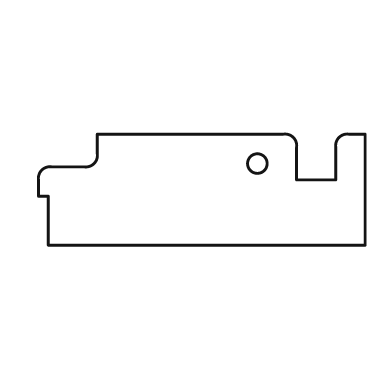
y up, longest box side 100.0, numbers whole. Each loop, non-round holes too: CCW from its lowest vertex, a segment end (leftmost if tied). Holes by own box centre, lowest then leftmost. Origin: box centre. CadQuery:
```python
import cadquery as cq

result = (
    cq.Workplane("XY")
    .moveTo(-47.0, -17.0)
    .lineTo(50.0, -17.0)
    .lineTo(50.0, 17.0)
    .lineTo(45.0, 17.0)
    .threePointArc((42.0, 16.0), (41.0, 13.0))
    .lineTo(41.0, 3.0)
    .lineTo(29.0, 3.0)
    .lineTo(29.0, 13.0)
    .threePointArc((28.0, 16.0), (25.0, 17.0))
    .lineTo(-32.0, 17.0)
    .lineTo(-32.0, 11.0)
    .threePointArc((-33.0, 8.0), (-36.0, 7.0))
    .lineTo(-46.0, 7.0)
    .threePointArc((-49.0, 6.0), (-50.0, 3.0))
    .lineTo(-50.0, -2.0)
    .lineTo(-47.0, -2.0)
    .close()
    .moveTo(17.0, 8.0)
    .circle(3.0)
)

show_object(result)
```